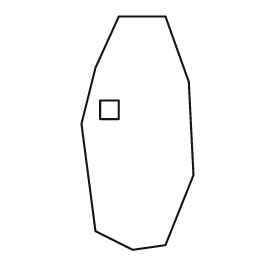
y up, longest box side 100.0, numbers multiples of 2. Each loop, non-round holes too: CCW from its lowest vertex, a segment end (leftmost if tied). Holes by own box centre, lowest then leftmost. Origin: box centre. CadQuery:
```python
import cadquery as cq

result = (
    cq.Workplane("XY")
    .moveTo(-2.0, -50.0)
    .lineTo(12.0, -48.0)
    .lineTo(24.0, -18.0)
    .lineTo(22.0, 22.0)
    .lineTo(12.0, 50.0)
    .lineTo(-8.0, 50.0)
    .lineTo(-18.0, 28.0)
    .lineTo(-24.0, 4.0)
    .lineTo(-18.0, -42.0)
    .close()
    .moveTo(-16.0, 6.0)
    .lineTo(-8.0, 6.0)
    .lineTo(-8.0, 14.0)
    .lineTo(-16.0, 14.0)
    .close()
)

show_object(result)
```